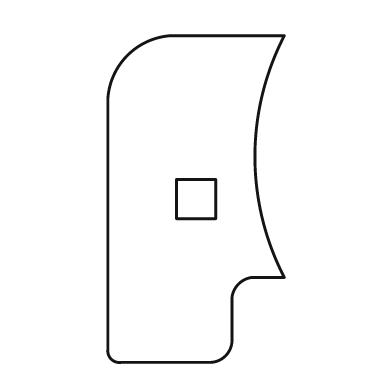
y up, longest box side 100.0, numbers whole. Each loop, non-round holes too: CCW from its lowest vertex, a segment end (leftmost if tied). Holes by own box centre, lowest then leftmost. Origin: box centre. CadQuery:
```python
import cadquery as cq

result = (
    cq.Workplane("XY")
    .moveTo(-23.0, -50.0)
    .lineTo(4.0, -50.0)
    .threePointArc((9.0, -48.0), (11.0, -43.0))
    .lineTo(11.0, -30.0)
    .threePointArc((13.0, -26.0), (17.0, -24.0))
    .lineTo(27.0, -24.0)
    .threePointArc((18.0, 13.0), (27.0, 50.0))
    .lineTo(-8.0, 50.0)
    .threePointArc((-21.0, 44.0), (-27.0, 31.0))
    .lineTo(-27.0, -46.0)
    .threePointArc((-26.0, -49.0), (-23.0, -50.0))
    .close()
    .moveTo(-6.0, -6.0)
    .lineTo(6.0, -6.0)
    .lineTo(6.0, 6.0)
    .lineTo(-6.0, 6.0)
    .close()
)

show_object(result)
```